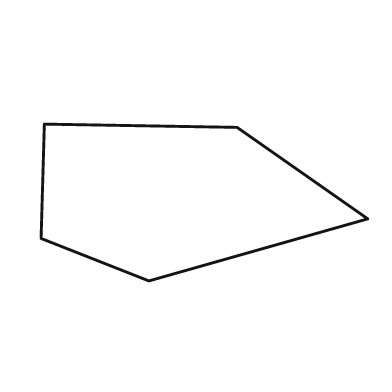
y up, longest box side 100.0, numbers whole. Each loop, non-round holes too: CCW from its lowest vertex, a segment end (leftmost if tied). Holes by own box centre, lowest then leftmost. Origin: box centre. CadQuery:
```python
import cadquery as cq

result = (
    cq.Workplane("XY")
    .moveTo(-17.0, -24.0)
    .lineTo(50.0, -5.0)
    .lineTo(10.0, 23.0)
    .lineTo(-49.0, 24.0)
    .lineTo(-50.0, -11.0)
    .close()
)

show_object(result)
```